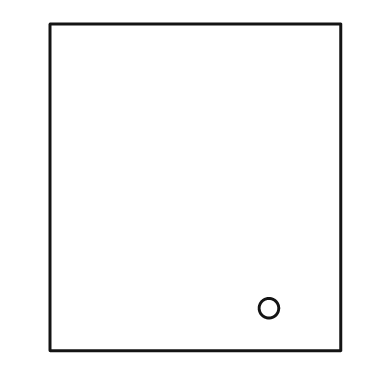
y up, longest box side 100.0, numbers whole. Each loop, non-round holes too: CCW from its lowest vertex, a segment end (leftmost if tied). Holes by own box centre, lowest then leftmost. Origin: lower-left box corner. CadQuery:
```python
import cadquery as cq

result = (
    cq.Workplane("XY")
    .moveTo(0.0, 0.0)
    .lineTo(89.0, 0.0)
    .lineTo(89.0, 100.0)
    .lineTo(0.0, 100.0)
    .close()
    .moveTo(67.0, 13.0)
    .circle(3.0)
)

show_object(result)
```